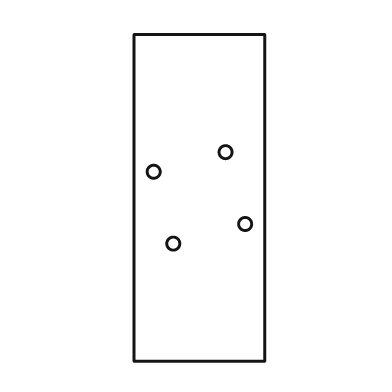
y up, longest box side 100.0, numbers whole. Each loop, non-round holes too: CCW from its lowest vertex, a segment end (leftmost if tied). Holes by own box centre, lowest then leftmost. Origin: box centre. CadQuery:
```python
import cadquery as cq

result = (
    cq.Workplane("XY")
    .moveTo(-20.0, -50.0)
    .lineTo(20.0, -50.0)
    .lineTo(20.0, 50.0)
    .lineTo(-20.0, 50.0)
    .close()
    .moveTo(-8.0, -14.0)
    .circle(2.0)
    .moveTo(14.0, -8.0)
    .circle(2.0)
    .moveTo(-14.0, 8.0)
    .circle(2.0)
    .moveTo(8.0, 14.0)
    .circle(2.0)
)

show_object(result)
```